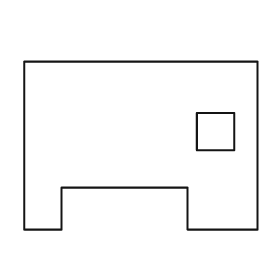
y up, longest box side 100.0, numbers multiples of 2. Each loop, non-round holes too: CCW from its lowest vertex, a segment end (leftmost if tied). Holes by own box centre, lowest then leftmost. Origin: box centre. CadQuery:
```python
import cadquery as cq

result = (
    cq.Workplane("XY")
    .moveTo(-50.0, -36.0)
    .lineTo(-34.0, -36.0)
    .lineTo(-34.0, -18.0)
    .lineTo(20.0, -18.0)
    .lineTo(20.0, -36.0)
    .lineTo(50.0, -36.0)
    .lineTo(50.0, 36.0)
    .lineTo(-50.0, 36.0)
    .close()
    .moveTo(24.0, -2.0)
    .lineTo(40.0, -2.0)
    .lineTo(40.0, 14.0)
    .lineTo(24.0, 14.0)
    .close()
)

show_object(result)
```